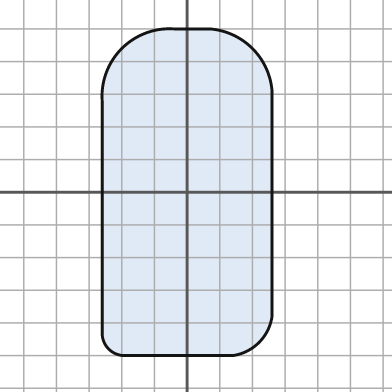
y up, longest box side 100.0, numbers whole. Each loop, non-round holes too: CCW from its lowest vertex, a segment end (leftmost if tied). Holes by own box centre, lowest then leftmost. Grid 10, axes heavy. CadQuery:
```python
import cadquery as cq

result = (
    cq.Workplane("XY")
    .moveTo(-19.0, -50.0)
    .lineTo(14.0, -50.0)
    .threePointArc((22.0, -46.0), (26.0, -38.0))
    .lineTo(26.0, 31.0)
    .threePointArc((20.0, 44.0), (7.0, 50.0))
    .lineTo(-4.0, 50.0)
    .threePointArc((-20.0, 44.0), (-26.0, 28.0))
    .lineTo(-26.0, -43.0)
    .threePointArc((-24.0, -48.0), (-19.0, -50.0))
    .close()
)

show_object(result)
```